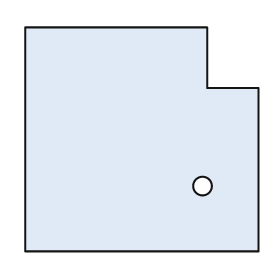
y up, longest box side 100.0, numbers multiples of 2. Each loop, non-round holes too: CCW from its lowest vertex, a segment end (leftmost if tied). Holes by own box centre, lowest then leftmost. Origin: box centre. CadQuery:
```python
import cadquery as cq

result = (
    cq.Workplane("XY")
    .moveTo(-50.0, -48.0)
    .lineTo(50.0, -48.0)
    .lineTo(50.0, 22.0)
    .lineTo(28.0, 22.0)
    .lineTo(28.0, 48.0)
    .lineTo(-50.0, 48.0)
    .close()
    .moveTo(26.0, -20.0)
    .circle(4.0)
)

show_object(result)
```